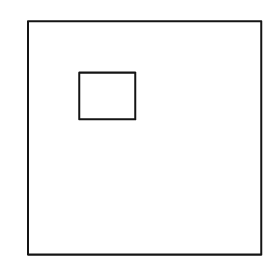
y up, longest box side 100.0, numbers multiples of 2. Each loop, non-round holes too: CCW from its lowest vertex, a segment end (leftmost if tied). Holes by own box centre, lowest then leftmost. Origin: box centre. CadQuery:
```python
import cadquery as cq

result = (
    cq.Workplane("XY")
    .moveTo(-50.0, -50.0)
    .lineTo(50.0, -50.0)
    .lineTo(50.0, 50.0)
    .lineTo(-50.0, 50.0)
    .close()
    .moveTo(-28.0, 8.0)
    .lineTo(-4.0, 8.0)
    .lineTo(-4.0, 28.0)
    .lineTo(-28.0, 28.0)
    .close()
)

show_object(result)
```